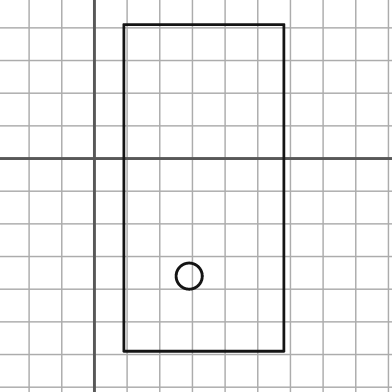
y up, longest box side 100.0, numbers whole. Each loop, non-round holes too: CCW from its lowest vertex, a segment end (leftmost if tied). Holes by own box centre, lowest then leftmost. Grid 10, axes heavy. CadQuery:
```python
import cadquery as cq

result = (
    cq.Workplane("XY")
    .moveTo(9.0, -59.0)
    .lineTo(58.0, -59.0)
    .lineTo(58.0, 41.0)
    .lineTo(9.0, 41.0)
    .close()
    .moveTo(29.0, -36.0)
    .circle(4.0)
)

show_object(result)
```